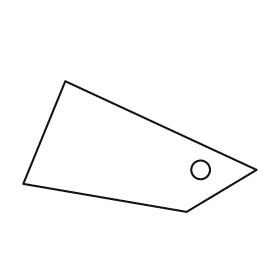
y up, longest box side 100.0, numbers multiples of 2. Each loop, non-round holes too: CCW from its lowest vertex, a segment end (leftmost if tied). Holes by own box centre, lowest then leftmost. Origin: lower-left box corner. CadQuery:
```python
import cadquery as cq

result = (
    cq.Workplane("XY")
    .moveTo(70.0, 0.0)
    .lineTo(100.0, 18.0)
    .lineTo(18.0, 56.0)
    .lineTo(0.0, 12.0)
    .close()
    .moveTo(76.0, 18.0)
    .circle(4.0)
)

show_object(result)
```